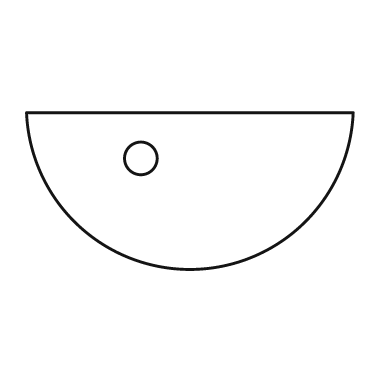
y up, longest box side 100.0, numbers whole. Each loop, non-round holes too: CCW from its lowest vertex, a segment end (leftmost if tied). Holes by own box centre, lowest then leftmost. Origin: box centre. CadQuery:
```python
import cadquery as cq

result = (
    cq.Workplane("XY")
    .moveTo(-50.0, 24.0)
    .threePointArc((0.0, -24.0), (50.0, 24.0))
    .close()
    .moveTo(-15.0, 10.0)
    .circle(5.0)
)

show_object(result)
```